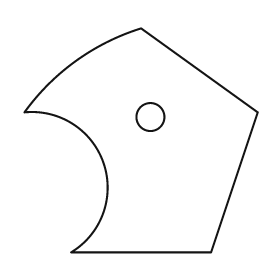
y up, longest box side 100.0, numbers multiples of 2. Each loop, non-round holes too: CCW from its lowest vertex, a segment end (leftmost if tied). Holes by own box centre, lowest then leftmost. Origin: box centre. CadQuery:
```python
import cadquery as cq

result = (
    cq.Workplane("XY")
    .moveTo(-30.0, -48.0)
    .lineTo(30.0, -48.0)
    .lineTo(50.0, 12.0)
    .lineTo(0.0, 48.0)
    .threePointArc((-28.0, 34.0), (-50.0, 12.0))
    .threePointArc((-16.0, -10.0), (-30.0, -48.0))
    .close()
    .moveTo(4.0, 10.0)
    .circle(6.0)
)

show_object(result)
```